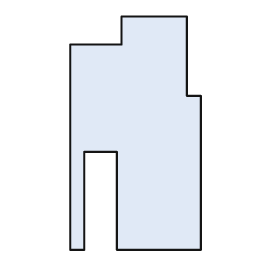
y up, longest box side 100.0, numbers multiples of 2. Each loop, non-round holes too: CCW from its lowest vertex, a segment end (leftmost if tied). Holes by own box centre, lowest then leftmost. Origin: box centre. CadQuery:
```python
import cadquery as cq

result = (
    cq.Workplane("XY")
    .moveTo(-28.0, -50.0)
    .lineTo(-22.0, -50.0)
    .lineTo(-22.0, -8.0)
    .lineTo(-8.0, -8.0)
    .lineTo(-8.0, -50.0)
    .lineTo(28.0, -50.0)
    .lineTo(28.0, 16.0)
    .lineTo(22.0, 16.0)
    .lineTo(22.0, 50.0)
    .lineTo(-6.0, 50.0)
    .lineTo(-6.0, 38.0)
    .lineTo(-28.0, 38.0)
    .close()
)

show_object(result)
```